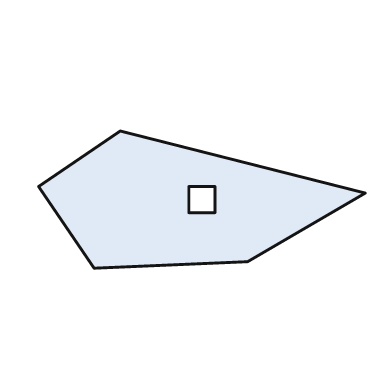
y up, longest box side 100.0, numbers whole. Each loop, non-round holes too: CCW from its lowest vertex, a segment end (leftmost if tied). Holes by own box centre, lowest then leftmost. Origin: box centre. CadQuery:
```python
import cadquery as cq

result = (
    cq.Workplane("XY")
    .moveTo(-33.0, -21.0)
    .lineTo(14.0, -19.0)
    .lineTo(50.0, 2.0)
    .lineTo(-25.0, 21.0)
    .lineTo(-50.0, 4.0)
    .close()
    .moveTo(-4.0, -4.0)
    .lineTo(4.0, -4.0)
    .lineTo(4.0, 4.0)
    .lineTo(-4.0, 4.0)
    .close()
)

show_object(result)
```